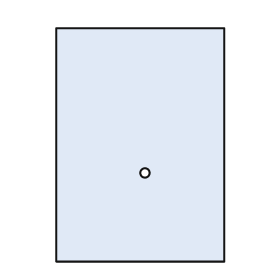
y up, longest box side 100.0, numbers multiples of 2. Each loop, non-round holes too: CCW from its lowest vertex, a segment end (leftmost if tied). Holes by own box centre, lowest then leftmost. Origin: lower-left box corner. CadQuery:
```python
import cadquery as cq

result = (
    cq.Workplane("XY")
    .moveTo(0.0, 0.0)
    .lineTo(72.0, 0.0)
    .lineTo(72.0, 100.0)
    .lineTo(0.0, 100.0)
    .close()
    .moveTo(38.0, 38.0)
    .circle(2.0)
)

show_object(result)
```